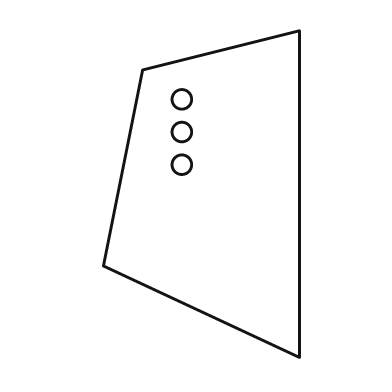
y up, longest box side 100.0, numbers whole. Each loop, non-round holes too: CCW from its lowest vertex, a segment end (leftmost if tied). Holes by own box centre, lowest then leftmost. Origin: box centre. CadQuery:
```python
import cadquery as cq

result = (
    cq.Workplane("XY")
    .moveTo(30.0, -50.0)
    .lineTo(30.0, 50.0)
    .lineTo(-18.0, 38.0)
    .lineTo(-30.0, -22.0)
    .close()
    .moveTo(-6.0, 9.0)
    .circle(3.0)
    .moveTo(-6.0, 19.0)
    .circle(3.0)
    .moveTo(-6.0, 29.0)
    .circle(3.0)
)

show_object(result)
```